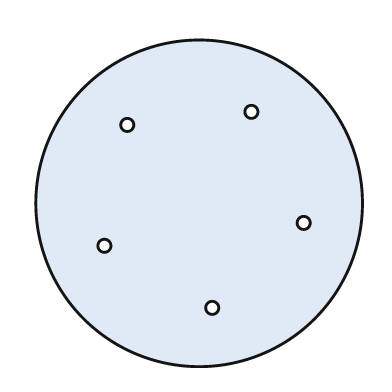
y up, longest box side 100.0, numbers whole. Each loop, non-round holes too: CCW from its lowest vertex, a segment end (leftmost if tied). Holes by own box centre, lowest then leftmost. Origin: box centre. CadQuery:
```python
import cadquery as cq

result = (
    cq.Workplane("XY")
    .moveTo(0.0, 0.0)
    .circle(50.0)
    .moveTo(4.0, -32.0)
    .circle(2.0)
    .moveTo(-29.0, -13.0)
    .circle(2.0)
    .moveTo(32.0, -6.0)
    .circle(2.0)
    .moveTo(-22.0, 24.0)
    .circle(2.0)
    .moveTo(16.0, 28.0)
    .circle(2.0)
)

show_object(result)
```